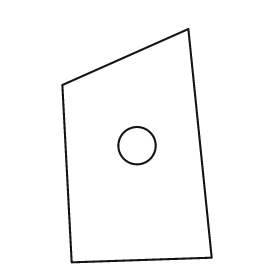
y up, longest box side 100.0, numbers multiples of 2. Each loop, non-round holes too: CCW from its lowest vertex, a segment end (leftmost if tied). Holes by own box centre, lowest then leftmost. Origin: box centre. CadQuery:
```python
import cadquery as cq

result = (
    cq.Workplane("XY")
    .moveTo(-28.0, -50.0)
    .lineTo(32.0, -48.0)
    .lineTo(22.0, 50.0)
    .lineTo(-32.0, 26.0)
    .close()
    .moveTo(0.0, 0.0)
    .circle(8.0)
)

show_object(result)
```